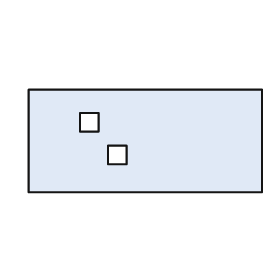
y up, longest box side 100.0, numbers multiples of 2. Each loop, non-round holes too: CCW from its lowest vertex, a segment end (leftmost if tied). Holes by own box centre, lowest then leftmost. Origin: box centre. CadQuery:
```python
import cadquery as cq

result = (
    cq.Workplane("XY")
    .moveTo(-50.0, -22.0)
    .lineTo(50.0, -22.0)
    .lineTo(50.0, 22.0)
    .lineTo(-50.0, 22.0)
    .close()
    .moveTo(-16.0, -10.0)
    .lineTo(-8.0, -10.0)
    .lineTo(-8.0, -2.0)
    .lineTo(-16.0, -2.0)
    .close()
    .moveTo(-28.0, 4.0)
    .lineTo(-20.0, 4.0)
    .lineTo(-20.0, 12.0)
    .lineTo(-28.0, 12.0)
    .close()
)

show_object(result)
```